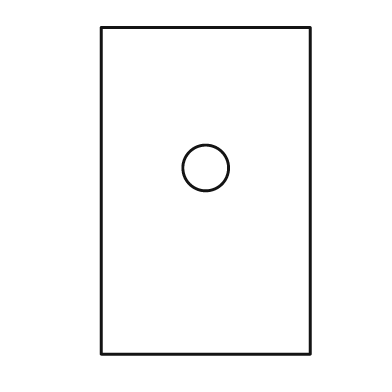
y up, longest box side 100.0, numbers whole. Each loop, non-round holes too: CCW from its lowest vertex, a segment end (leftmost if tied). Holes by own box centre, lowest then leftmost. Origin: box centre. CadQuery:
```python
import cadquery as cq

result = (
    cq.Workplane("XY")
    .moveTo(-32.0, -50.0)
    .lineTo(32.0, -50.0)
    .lineTo(32.0, 50.0)
    .lineTo(-32.0, 50.0)
    .close()
    .moveTo(0.0, 7.0)
    .circle(7.0)
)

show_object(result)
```